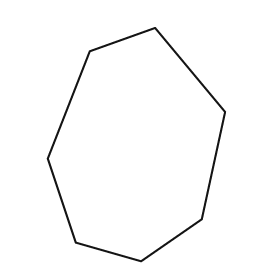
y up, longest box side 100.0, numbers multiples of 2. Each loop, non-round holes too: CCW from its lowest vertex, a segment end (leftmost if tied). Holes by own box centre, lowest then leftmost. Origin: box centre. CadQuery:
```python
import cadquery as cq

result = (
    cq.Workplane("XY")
    .moveTo(2.0, -50.0)
    .lineTo(28.0, -32.0)
    .lineTo(38.0, 14.0)
    .lineTo(8.0, 50.0)
    .lineTo(-20.0, 40.0)
    .lineTo(-38.0, -6.0)
    .lineTo(-26.0, -42.0)
    .close()
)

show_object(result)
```